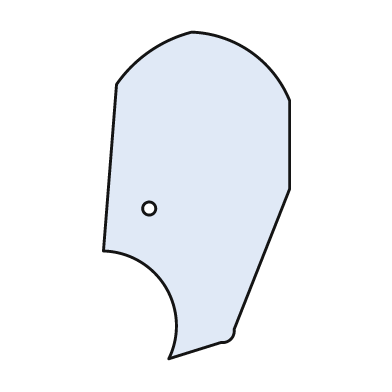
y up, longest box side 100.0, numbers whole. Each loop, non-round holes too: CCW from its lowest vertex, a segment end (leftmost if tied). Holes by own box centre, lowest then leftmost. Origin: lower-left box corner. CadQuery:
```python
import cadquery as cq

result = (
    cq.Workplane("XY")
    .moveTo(20.0, 0.0)
    .lineTo(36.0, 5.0)
    .threePointArc((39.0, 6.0), (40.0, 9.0))
    .lineTo(57.0, 52.0)
    .lineTo(57.0, 79.0)
    .threePointArc((45.0, 94.0), (27.0, 100.0))
    .threePointArc((14.0, 94.0), (4.0, 84.0))
    .lineTo(0.0, 33.0)
    .threePointArc((19.0, 22.0), (20.0, 0.0))
    .close()
    .moveTo(14.0, 46.0)
    .circle(2.0)
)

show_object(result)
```